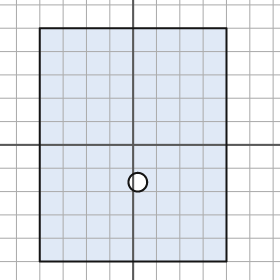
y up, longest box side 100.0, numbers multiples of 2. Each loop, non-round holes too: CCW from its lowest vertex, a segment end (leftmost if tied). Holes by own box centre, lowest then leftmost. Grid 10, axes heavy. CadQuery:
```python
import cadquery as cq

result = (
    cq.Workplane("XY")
    .moveTo(-40.0, -50.0)
    .lineTo(40.0, -50.0)
    .lineTo(40.0, 50.0)
    .lineTo(-40.0, 50.0)
    .close()
    .moveTo(2.0, -16.0)
    .circle(4.0)
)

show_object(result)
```